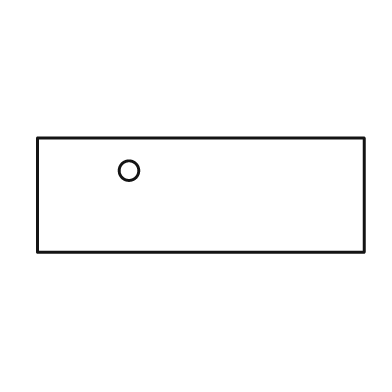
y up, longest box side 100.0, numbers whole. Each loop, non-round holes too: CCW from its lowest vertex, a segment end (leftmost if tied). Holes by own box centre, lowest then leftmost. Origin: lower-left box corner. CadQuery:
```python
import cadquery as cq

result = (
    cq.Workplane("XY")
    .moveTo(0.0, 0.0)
    .lineTo(100.0, 0.0)
    .lineTo(100.0, 35.0)
    .lineTo(0.0, 35.0)
    .close()
    .moveTo(28.0, 25.0)
    .circle(3.0)
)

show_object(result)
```